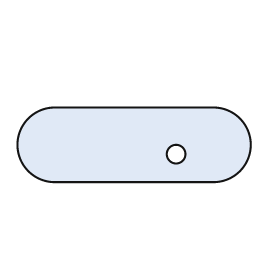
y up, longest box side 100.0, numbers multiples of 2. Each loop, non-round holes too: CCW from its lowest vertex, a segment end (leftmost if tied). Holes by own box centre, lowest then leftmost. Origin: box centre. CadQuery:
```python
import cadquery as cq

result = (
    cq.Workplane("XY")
    .moveTo(-34.0, -16.0)
    .lineTo(34.0, -16.0)
    .threePointArc((50.0, 0.0), (34.0, 16.0))
    .lineTo(-34.0, 16.0)
    .threePointArc((-50.0, 0.0), (-34.0, -16.0))
    .close()
    .moveTo(18.0, -4.0)
    .circle(4.0)
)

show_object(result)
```